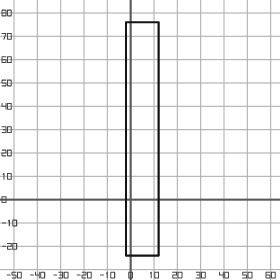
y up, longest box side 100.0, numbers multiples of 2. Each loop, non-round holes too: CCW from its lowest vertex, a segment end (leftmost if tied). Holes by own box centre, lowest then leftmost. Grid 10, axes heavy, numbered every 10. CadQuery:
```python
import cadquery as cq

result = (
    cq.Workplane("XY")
    .moveTo(-2.0, -24.0)
    .lineTo(12.0, -24.0)
    .lineTo(12.0, 76.0)
    .lineTo(-2.0, 76.0)
    .close()
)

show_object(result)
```